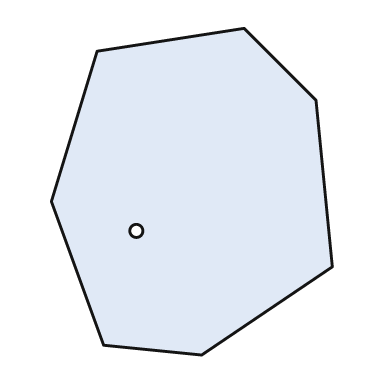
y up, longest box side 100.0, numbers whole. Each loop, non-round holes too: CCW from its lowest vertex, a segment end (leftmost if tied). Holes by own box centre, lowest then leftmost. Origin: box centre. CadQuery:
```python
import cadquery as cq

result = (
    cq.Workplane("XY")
    .moveTo(3.0, -50.0)
    .lineTo(43.0, -23.0)
    .lineTo(38.0, 28.0)
    .lineTo(16.0, 50.0)
    .lineTo(-29.0, 43.0)
    .lineTo(-43.0, -3.0)
    .lineTo(-27.0, -47.0)
    .close()
    .moveTo(-17.0, -12.0)
    .circle(2.0)
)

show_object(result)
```